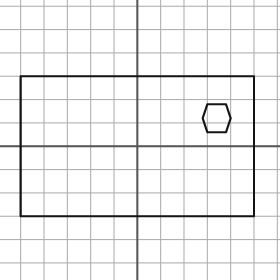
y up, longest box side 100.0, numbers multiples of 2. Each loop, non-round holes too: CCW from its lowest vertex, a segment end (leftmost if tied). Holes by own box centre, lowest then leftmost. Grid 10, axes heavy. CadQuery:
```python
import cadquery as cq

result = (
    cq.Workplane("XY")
    .moveTo(-50.0, -30.0)
    .lineTo(50.0, -30.0)
    .lineTo(50.0, 30.0)
    .lineTo(-50.0, 30.0)
    .close()
    .moveTo(30.0, 6.0)
    .lineTo(38.0, 6.0)
    .lineTo(40.0, 12.0)
    .lineTo(38.0, 18.0)
    .lineTo(30.0, 18.0)
    .lineTo(28.0, 12.0)
    .close()
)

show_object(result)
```